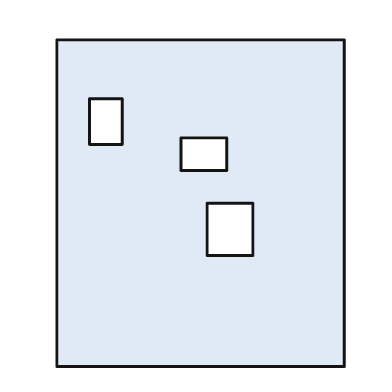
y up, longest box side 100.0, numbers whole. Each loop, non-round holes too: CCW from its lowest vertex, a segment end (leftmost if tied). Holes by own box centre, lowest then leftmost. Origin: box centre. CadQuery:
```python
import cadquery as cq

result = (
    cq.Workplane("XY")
    .moveTo(-44.0, -50.0)
    .lineTo(44.0, -50.0)
    .lineTo(44.0, 50.0)
    .lineTo(-44.0, 50.0)
    .close()
    .moveTo(2.0, -16.0)
    .lineTo(16.0, -16.0)
    .lineTo(16.0, 0.0)
    .lineTo(2.0, 0.0)
    .close()
    .moveTo(-6.0, 10.0)
    .lineTo(8.0, 10.0)
    .lineTo(8.0, 20.0)
    .lineTo(-6.0, 20.0)
    .close()
    .moveTo(-34.0, 18.0)
    .lineTo(-24.0, 18.0)
    .lineTo(-24.0, 32.0)
    .lineTo(-34.0, 32.0)
    .close()
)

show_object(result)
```